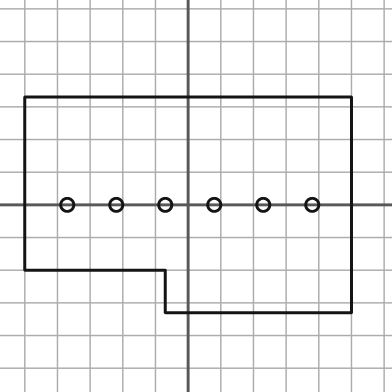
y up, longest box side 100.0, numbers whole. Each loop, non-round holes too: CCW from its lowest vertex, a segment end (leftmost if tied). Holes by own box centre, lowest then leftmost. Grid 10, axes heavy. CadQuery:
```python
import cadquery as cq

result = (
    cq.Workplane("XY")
    .moveTo(-7.0, -33.0)
    .lineTo(50.0, -33.0)
    .lineTo(50.0, 33.0)
    .lineTo(-50.0, 33.0)
    .lineTo(-50.0, -20.0)
    .lineTo(-7.0, -20.0)
    .close()
    .moveTo(-37.0, 0.0)
    .circle(2.0)
    .moveTo(-22.0, 0.0)
    .circle(2.0)
    .moveTo(-7.0, 0.0)
    .circle(2.0)
    .moveTo(8.0, 0.0)
    .circle(2.0)
    .moveTo(23.0, 0.0)
    .circle(2.0)
    .moveTo(38.0, 0.0)
    .circle(2.0)
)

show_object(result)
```